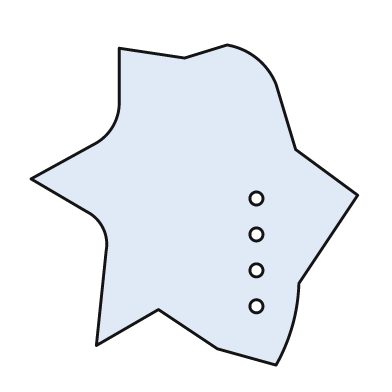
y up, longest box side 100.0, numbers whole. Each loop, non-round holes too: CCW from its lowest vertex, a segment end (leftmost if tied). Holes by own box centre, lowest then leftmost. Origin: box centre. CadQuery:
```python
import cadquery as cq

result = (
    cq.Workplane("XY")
    .moveTo(25.0, -49.0)
    .threePointArc((30.0, -37.0), (32.0, -24.0))
    .lineTo(50.0, 3.0)
    .lineTo(31.0, 17.0)
    .lineTo(25.0, 37.0)
    .threePointArc((19.0, 45.0), (10.0, 49.0))
    .lineTo(-3.0, 45.0)
    .lineTo(-23.0, 48.0)
    .lineTo(-23.0, 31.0)
    .threePointArc((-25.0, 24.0), (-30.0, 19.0))
    .lineTo(-50.0, 8.0)
    .lineTo(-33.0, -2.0)
    .threePointArc((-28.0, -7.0), (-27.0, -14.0))
    .lineTo(-30.0, -43.0)
    .lineTo(-11.0, -32.0)
    .lineTo(7.0, -44.0)
    .close()
    .moveTo(19.0, -31.0)
    .circle(2.0)
    .moveTo(19.0, -20.0)
    .circle(2.0)
    .moveTo(19.0, -9.0)
    .circle(2.0)
    .moveTo(19.0, 2.0)
    .circle(2.0)
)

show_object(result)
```